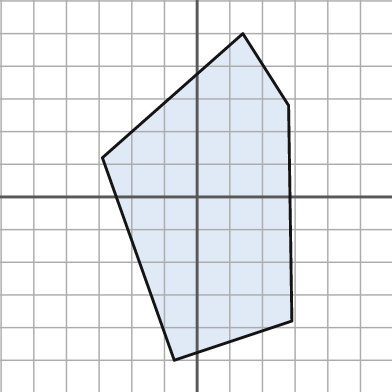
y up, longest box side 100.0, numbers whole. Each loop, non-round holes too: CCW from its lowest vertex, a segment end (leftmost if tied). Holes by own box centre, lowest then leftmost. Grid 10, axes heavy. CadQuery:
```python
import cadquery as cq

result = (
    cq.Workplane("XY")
    .moveTo(-7.0, -50.0)
    .lineTo(29.0, -38.0)
    .lineTo(28.0, 28.0)
    .lineTo(14.0, 50.0)
    .lineTo(-29.0, 12.0)
    .close()
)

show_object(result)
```